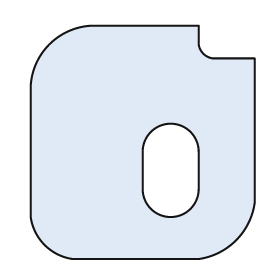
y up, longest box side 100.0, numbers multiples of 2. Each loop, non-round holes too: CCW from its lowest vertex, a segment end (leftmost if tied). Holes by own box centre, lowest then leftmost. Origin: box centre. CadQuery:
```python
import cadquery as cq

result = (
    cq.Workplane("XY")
    .moveTo(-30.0, -50.0)
    .lineTo(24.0, -50.0)
    .threePointArc((40.0, -42.0), (48.0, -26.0))
    .lineTo(48.0, 36.0)
    .lineTo(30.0, 36.0)
    .threePointArc((26.0, 38.0), (24.0, 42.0))
    .lineTo(24.0, 50.0)
    .lineTo(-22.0, 50.0)
    .threePointArc((-40.0, 42.0), (-48.0, 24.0))
    .lineTo(-48.0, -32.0)
    .threePointArc((-42.0, -44.0), (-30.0, -50.0))
    .close()
    .moveTo(0.0, -20.0)
    .threePointArc((12.0, -32.0), (24.0, -20.0))
    .lineTo(24.0, -4.0)
    .threePointArc((12.0, 8.0), (0.0, -4.0))
    .close()
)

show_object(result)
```